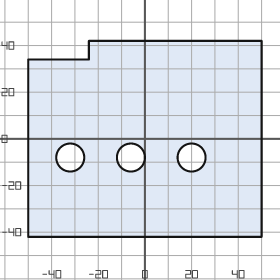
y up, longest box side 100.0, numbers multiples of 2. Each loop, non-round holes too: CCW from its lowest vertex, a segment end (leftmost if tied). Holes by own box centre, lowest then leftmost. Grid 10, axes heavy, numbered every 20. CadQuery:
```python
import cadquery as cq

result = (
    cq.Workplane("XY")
    .moveTo(-50.0, -42.0)
    .lineTo(50.0, -42.0)
    .lineTo(50.0, 42.0)
    .lineTo(-24.0, 42.0)
    .lineTo(-24.0, 34.0)
    .lineTo(-50.0, 34.0)
    .close()
    .moveTo(-32.0, -8.0)
    .circle(6.0)
    .moveTo(-6.0, -8.0)
    .circle(6.0)
    .moveTo(20.0, -8.0)
    .circle(6.0)
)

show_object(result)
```